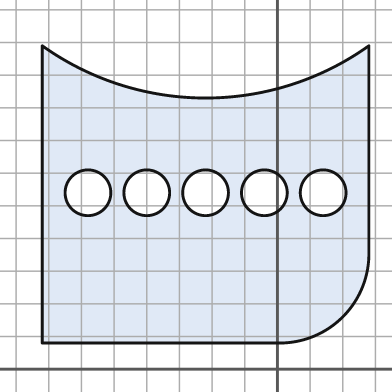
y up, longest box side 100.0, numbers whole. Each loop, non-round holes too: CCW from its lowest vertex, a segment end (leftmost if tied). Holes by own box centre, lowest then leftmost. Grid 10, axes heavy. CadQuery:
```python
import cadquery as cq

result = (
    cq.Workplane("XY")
    .moveTo(-72.0, 8.0)
    .lineTo(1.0, 8.0)
    .threePointArc((20.0, 16.0), (28.0, 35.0))
    .lineTo(28.0, 99.0)
    .threePointArc((-22.0, 83.0), (-72.0, 99.0))
    .close()
    .moveTo(-58.0, 54.0)
    .circle(7.0)
    .moveTo(-40.0, 54.0)
    .circle(7.0)
    .moveTo(-22.0, 54.0)
    .circle(7.0)
    .moveTo(-4.0, 54.0)
    .circle(7.0)
    .moveTo(14.0, 54.0)
    .circle(7.0)
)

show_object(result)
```